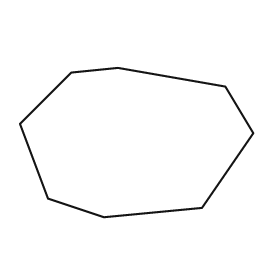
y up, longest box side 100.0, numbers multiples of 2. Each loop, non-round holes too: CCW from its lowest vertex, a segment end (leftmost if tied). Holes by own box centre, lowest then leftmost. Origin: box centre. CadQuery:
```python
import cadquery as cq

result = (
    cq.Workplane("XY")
    .moveTo(-14.0, -32.0)
    .lineTo(28.0, -28.0)
    .lineTo(50.0, 4.0)
    .lineTo(38.0, 24.0)
    .lineTo(-8.0, 32.0)
    .lineTo(-28.0, 30.0)
    .lineTo(-50.0, 8.0)
    .lineTo(-38.0, -24.0)
    .close()
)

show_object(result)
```